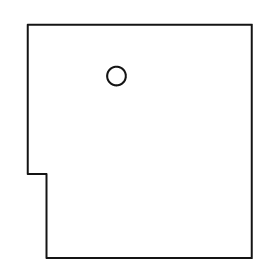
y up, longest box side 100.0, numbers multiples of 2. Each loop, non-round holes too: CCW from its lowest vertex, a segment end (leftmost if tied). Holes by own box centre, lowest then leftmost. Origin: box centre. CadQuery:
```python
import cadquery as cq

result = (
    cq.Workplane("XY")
    .moveTo(-40.0, -50.0)
    .lineTo(48.0, -50.0)
    .lineTo(48.0, 50.0)
    .lineTo(-48.0, 50.0)
    .lineTo(-48.0, -14.0)
    .lineTo(-40.0, -14.0)
    .close()
    .moveTo(-10.0, 28.0)
    .circle(4.0)
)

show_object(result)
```